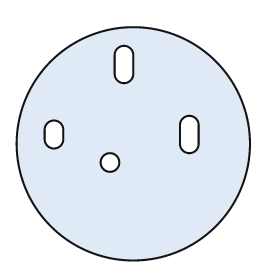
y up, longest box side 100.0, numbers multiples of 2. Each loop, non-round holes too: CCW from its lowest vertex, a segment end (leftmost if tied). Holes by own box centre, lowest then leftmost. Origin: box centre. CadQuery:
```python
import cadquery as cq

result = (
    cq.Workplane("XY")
    .moveTo(0.0, 0.0)
    .circle(50.0)
    .moveTo(-10.0, -8.0)
    .circle(4.0)
    .moveTo(-38.0, 2.0)
    .threePointArc((-34.0, -2.0), (-30.0, 2.0))
    .lineTo(-30.0, 6.0)
    .threePointArc((-34.0, 10.0), (-38.0, 6.0))
    .close()
    .moveTo(20.0, 0.0)
    .threePointArc((24.0, -4.0), (28.0, 0.0))
    .lineTo(28.0, 8.0)
    .threePointArc((24.0, 12.0), (20.0, 8.0))
    .close()
    .moveTo(-8.0, 30.0)
    .threePointArc((-4.0, 26.0), (0.0, 30.0))
    .lineTo(0.0, 38.0)
    .threePointArc((-4.0, 42.0), (-8.0, 38.0))
    .close()
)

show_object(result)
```